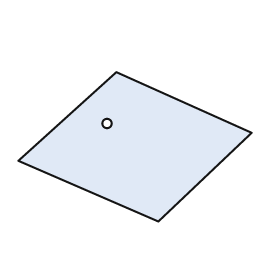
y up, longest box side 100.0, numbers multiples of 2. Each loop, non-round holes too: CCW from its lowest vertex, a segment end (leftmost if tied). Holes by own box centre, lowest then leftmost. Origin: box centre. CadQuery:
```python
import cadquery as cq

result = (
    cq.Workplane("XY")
    .moveTo(10.0, -32.0)
    .lineTo(50.0, 6.0)
    .lineTo(-8.0, 32.0)
    .lineTo(-50.0, -6.0)
    .close()
    .moveTo(-12.0, 10.0)
    .circle(2.0)
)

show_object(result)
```